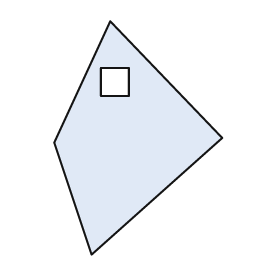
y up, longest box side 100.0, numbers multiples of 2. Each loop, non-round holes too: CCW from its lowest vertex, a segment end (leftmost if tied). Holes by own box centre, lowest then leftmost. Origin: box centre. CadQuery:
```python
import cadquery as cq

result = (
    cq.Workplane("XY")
    .moveTo(-20.0, -50.0)
    .lineTo(36.0, 0.0)
    .lineTo(-12.0, 50.0)
    .lineTo(-36.0, -2.0)
    .close()
    .moveTo(-16.0, 18.0)
    .lineTo(-4.0, 18.0)
    .lineTo(-4.0, 30.0)
    .lineTo(-16.0, 30.0)
    .close()
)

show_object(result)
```